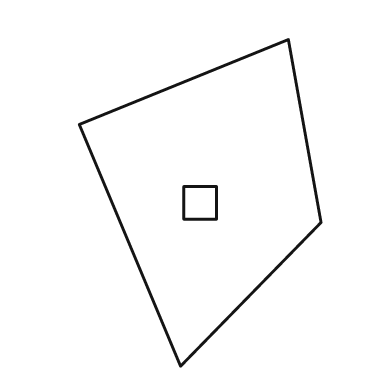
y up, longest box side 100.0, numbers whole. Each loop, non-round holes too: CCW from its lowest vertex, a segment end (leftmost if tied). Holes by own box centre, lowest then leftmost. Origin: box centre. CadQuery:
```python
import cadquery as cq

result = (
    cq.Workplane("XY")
    .moveTo(-6.0, -50.0)
    .lineTo(37.0, -6.0)
    .lineTo(27.0, 50.0)
    .lineTo(-37.0, 24.0)
    .close()
    .moveTo(-5.0, -5.0)
    .lineTo(5.0, -5.0)
    .lineTo(5.0, 5.0)
    .lineTo(-5.0, 5.0)
    .close()
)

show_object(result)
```